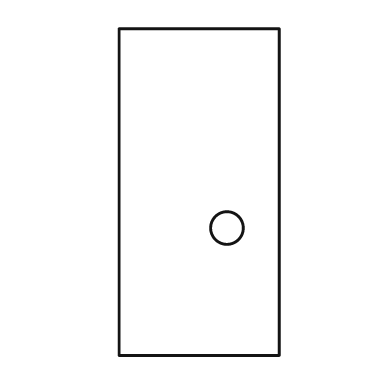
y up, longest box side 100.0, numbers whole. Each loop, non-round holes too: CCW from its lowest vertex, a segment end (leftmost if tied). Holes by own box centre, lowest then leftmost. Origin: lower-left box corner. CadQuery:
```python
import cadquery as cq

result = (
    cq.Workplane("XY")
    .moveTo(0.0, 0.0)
    .lineTo(49.0, 0.0)
    .lineTo(49.0, 100.0)
    .lineTo(0.0, 100.0)
    .close()
    .moveTo(33.0, 39.0)
    .circle(5.0)
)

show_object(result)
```